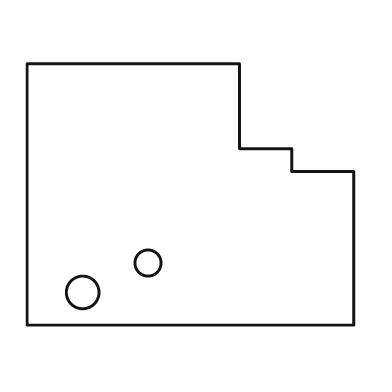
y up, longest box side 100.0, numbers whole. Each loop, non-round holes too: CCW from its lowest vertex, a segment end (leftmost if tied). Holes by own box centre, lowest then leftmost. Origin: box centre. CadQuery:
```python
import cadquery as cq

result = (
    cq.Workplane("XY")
    .moveTo(-50.0, -40.0)
    .lineTo(50.0, -40.0)
    .lineTo(50.0, 7.0)
    .lineTo(31.0, 7.0)
    .lineTo(31.0, 14.0)
    .lineTo(15.0, 14.0)
    .lineTo(15.0, 40.0)
    .lineTo(-50.0, 40.0)
    .close()
    .moveTo(-33.0, -30.0)
    .circle(5.0)
    .moveTo(-13.0, -21.0)
    .circle(4.0)
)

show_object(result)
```